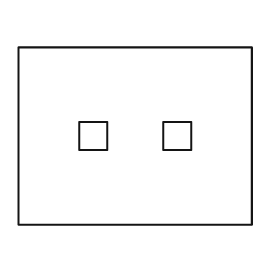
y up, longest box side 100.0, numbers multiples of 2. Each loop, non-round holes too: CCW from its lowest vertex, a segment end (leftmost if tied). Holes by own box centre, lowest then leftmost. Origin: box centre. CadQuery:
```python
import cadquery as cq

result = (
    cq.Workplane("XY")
    .moveTo(-50.0, -38.0)
    .lineTo(50.0, -38.0)
    .lineTo(50.0, 38.0)
    .lineTo(-50.0, 38.0)
    .close()
    .moveTo(-24.0, -6.0)
    .lineTo(-12.0, -6.0)
    .lineTo(-12.0, 6.0)
    .lineTo(-24.0, 6.0)
    .close()
    .moveTo(12.0, -6.0)
    .lineTo(24.0, -6.0)
    .lineTo(24.0, 6.0)
    .lineTo(12.0, 6.0)
    .close()
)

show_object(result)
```